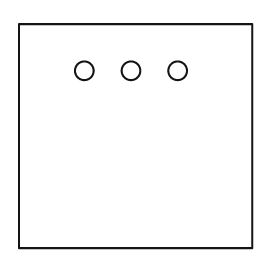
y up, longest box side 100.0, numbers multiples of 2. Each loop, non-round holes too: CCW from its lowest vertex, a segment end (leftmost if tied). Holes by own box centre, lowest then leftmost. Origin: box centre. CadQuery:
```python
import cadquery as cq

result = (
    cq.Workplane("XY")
    .moveTo(-50.0, -48.0)
    .lineTo(50.0, -48.0)
    .lineTo(50.0, 48.0)
    .lineTo(-50.0, 48.0)
    .close()
    .moveTo(-22.0, 28.0)
    .circle(4.0)
    .moveTo(-2.0, 28.0)
    .circle(4.0)
    .moveTo(18.0, 28.0)
    .circle(4.0)
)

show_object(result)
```